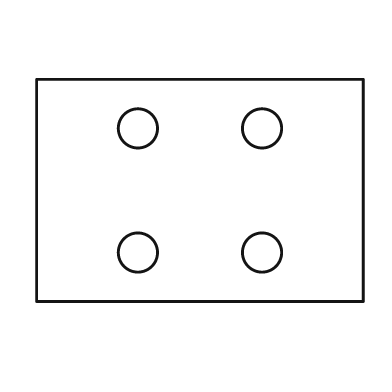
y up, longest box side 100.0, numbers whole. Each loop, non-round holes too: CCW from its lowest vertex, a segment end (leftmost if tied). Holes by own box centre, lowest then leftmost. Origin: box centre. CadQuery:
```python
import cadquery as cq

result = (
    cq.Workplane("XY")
    .moveTo(-50.0, -34.0)
    .lineTo(50.0, -34.0)
    .lineTo(50.0, 34.0)
    .lineTo(-50.0, 34.0)
    .close()
    .moveTo(-19.0, -19.0)
    .circle(6.0)
    .moveTo(19.0, -19.0)
    .circle(6.0)
    .moveTo(-19.0, 19.0)
    .circle(6.0)
    .moveTo(19.0, 19.0)
    .circle(6.0)
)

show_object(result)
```